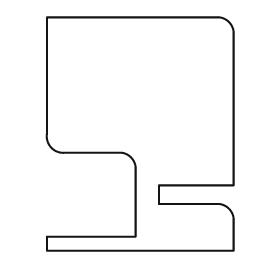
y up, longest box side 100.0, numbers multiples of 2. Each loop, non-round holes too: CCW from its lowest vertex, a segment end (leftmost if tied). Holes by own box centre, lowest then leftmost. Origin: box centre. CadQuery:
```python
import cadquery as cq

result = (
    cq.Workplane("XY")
    .moveTo(-40.0, -50.0)
    .lineTo(40.0, -50.0)
    .lineTo(40.0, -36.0)
    .threePointArc((38.0, -32.0), (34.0, -30.0))
    .lineTo(8.0, -30.0)
    .lineTo(8.0, -22.0)
    .lineTo(40.0, -22.0)
    .lineTo(40.0, 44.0)
    .threePointArc((38.0, 48.0), (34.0, 50.0))
    .lineTo(-40.0, 50.0)
    .lineTo(-40.0, 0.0)
    .threePointArc((-38.0, -6.0), (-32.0, -8.0))
    .lineTo(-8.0, -8.0)
    .threePointArc((-4.0, -10.0), (-2.0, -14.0))
    .lineTo(-2.0, -44.0)
    .lineTo(-40.0, -44.0)
    .close()
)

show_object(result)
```